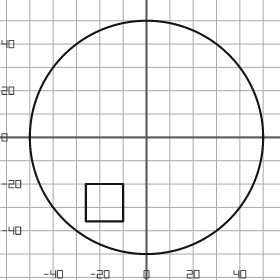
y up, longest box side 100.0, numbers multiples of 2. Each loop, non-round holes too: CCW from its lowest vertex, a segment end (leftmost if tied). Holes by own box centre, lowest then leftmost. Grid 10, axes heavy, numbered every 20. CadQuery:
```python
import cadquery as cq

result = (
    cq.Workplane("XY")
    .moveTo(0.0, 0.0)
    .circle(50.0)
    .moveTo(-26.0, -36.0)
    .lineTo(-10.0, -36.0)
    .lineTo(-10.0, -20.0)
    .lineTo(-26.0, -20.0)
    .close()
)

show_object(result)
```